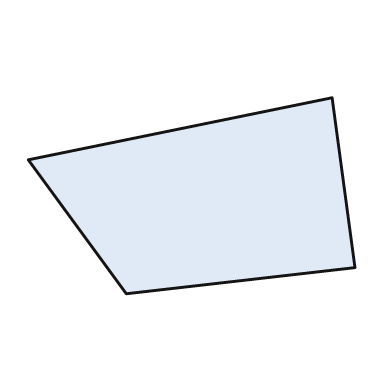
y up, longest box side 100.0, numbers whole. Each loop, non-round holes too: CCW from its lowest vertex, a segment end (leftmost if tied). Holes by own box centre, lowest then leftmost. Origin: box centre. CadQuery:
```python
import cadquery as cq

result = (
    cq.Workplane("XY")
    .moveTo(-20.0, -30.0)
    .lineTo(50.0, -22.0)
    .lineTo(43.0, 30.0)
    .lineTo(-50.0, 11.0)
    .close()
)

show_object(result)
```